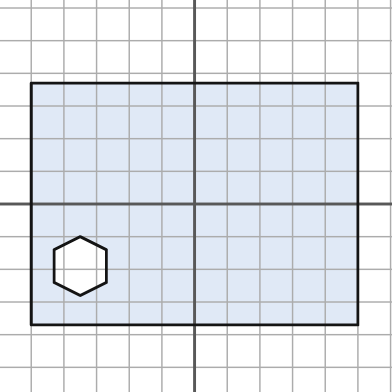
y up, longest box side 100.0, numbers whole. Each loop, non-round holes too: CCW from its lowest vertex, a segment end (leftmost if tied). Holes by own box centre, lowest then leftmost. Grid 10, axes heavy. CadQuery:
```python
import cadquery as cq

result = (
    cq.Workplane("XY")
    .moveTo(-50.0, -37.0)
    .lineTo(50.0, -37.0)
    .lineTo(50.0, 37.0)
    .lineTo(-50.0, 37.0)
    .close()
    .moveTo(-35.0, -28.0)
    .lineTo(-27.0, -24.0)
    .lineTo(-27.0, -14.0)
    .lineTo(-35.0, -10.0)
    .lineTo(-43.0, -14.0)
    .lineTo(-43.0, -24.0)
    .close()
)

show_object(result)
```